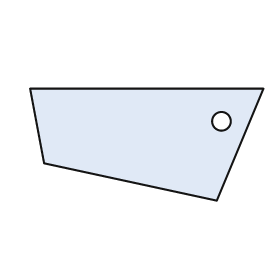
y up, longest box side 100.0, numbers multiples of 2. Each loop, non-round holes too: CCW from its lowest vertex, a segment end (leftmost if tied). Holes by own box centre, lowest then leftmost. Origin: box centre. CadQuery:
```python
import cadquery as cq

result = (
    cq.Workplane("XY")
    .moveTo(30.0, -24.0)
    .lineTo(50.0, 24.0)
    .lineTo(-50.0, 24.0)
    .lineTo(-44.0, -8.0)
    .close()
    .moveTo(32.0, 10.0)
    .circle(4.0)
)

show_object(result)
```